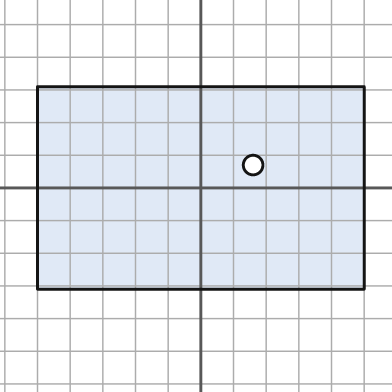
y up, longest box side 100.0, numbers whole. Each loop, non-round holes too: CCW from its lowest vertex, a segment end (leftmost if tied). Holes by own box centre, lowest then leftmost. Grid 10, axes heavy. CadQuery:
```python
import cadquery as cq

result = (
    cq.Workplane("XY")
    .moveTo(-50.0, -31.0)
    .lineTo(50.0, -31.0)
    .lineTo(50.0, 31.0)
    .lineTo(-50.0, 31.0)
    .close()
    .moveTo(16.0, 7.0)
    .circle(3.0)
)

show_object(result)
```